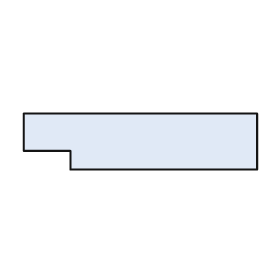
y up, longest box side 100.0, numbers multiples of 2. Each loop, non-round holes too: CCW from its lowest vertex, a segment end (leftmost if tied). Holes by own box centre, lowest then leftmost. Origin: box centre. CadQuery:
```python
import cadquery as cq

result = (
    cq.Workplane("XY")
    .moveTo(-30.0, -12.0)
    .lineTo(50.0, -12.0)
    .lineTo(50.0, 12.0)
    .lineTo(-50.0, 12.0)
    .lineTo(-50.0, -4.0)
    .lineTo(-30.0, -4.0)
    .close()
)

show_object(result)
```